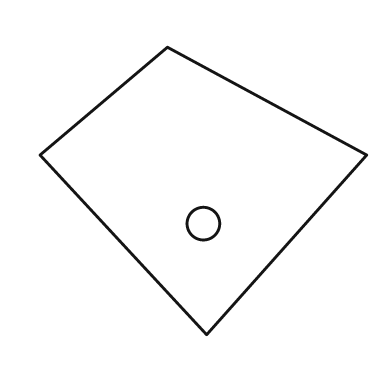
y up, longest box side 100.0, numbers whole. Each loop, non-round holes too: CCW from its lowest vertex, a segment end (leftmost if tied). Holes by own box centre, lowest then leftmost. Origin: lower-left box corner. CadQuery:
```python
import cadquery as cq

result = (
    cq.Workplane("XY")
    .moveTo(51.0, 0.0)
    .lineTo(100.0, 55.0)
    .lineTo(39.0, 88.0)
    .lineTo(0.0, 55.0)
    .close()
    .moveTo(50.0, 34.0)
    .circle(5.0)
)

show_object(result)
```